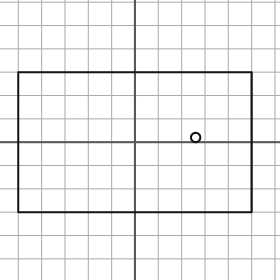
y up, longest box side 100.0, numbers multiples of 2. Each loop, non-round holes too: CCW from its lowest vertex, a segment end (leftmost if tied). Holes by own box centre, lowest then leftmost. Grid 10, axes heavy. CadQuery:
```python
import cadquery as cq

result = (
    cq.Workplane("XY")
    .moveTo(-50.0, -30.0)
    .lineTo(50.0, -30.0)
    .lineTo(50.0, 30.0)
    .lineTo(-50.0, 30.0)
    .close()
    .moveTo(26.0, 2.0)
    .circle(2.0)
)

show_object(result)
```